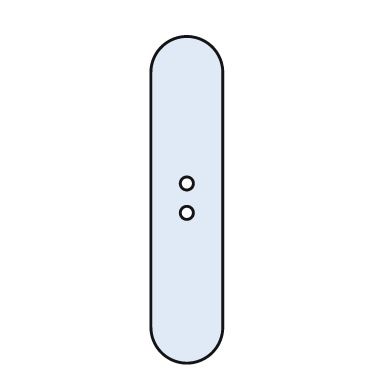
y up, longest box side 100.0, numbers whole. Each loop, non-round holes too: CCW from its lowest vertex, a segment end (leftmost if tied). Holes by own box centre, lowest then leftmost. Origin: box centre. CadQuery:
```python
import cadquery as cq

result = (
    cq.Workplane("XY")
    .moveTo(-11.0, -39.0)
    .threePointArc((0.0, -50.0), (11.0, -39.0))
    .lineTo(11.0, 39.0)
    .threePointArc((0.0, 50.0), (-11.0, 39.0))
    .close()
    .moveTo(0.0, -4.0)
    .circle(2.0)
    .moveTo(0.0, 5.0)
    .circle(2.0)
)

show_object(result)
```